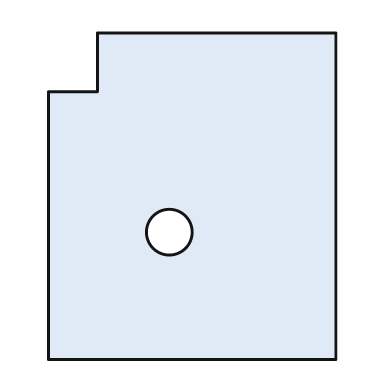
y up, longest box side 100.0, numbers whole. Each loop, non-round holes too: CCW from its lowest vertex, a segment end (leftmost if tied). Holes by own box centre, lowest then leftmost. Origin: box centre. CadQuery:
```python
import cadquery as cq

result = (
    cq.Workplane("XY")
    .moveTo(-44.0, -50.0)
    .lineTo(44.0, -50.0)
    .lineTo(44.0, 50.0)
    .lineTo(-29.0, 50.0)
    .lineTo(-29.0, 32.0)
    .lineTo(-44.0, 32.0)
    .close()
    .moveTo(-7.0, -11.0)
    .circle(7.0)
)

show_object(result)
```